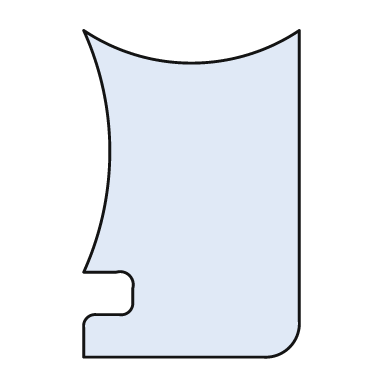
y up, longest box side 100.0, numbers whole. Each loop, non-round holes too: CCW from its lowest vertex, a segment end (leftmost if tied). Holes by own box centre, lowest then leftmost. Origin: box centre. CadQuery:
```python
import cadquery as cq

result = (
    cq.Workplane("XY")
    .moveTo(-33.0, -50.0)
    .lineTo(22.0, -50.0)
    .threePointArc((30.0, -47.0), (33.0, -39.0))
    .lineTo(33.0, 50.0)
    .threePointArc((0.0, 40.0), (-33.0, 50.0))
    .threePointArc((-25.0, 13.0), (-33.0, -24.0))
    .lineTo(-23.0, -24.0)
    .threePointArc((-19.0, -25.0), (-18.0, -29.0))
    .lineTo(-18.0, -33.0)
    .threePointArc((-19.0, -36.0), (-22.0, -37.0))
    .lineTo(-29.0, -37.0)
    .threePointArc((-32.0, -38.0), (-33.0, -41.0))
    .close()
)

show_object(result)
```